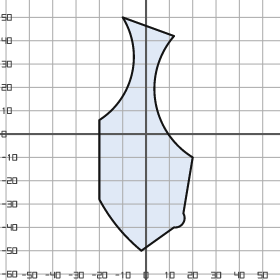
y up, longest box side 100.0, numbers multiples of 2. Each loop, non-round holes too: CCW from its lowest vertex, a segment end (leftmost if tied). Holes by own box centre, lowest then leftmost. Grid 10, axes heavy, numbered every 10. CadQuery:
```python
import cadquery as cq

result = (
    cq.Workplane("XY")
    .moveTo(-2.0, -50.0)
    .lineTo(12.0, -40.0)
    .threePointArc((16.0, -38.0), (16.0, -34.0))
    .lineTo(20.0, -10.0)
    .threePointArc((4.0, 14.0), (12.0, 42.0))
    .lineTo(-10.0, 50.0)
    .threePointArc((-6.0, 26.0), (-20.0, 6.0))
    .lineTo(-20.0, -28.0)
    .threePointArc((-12.0, -40.0), (-2.0, -50.0))
    .close()
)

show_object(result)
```